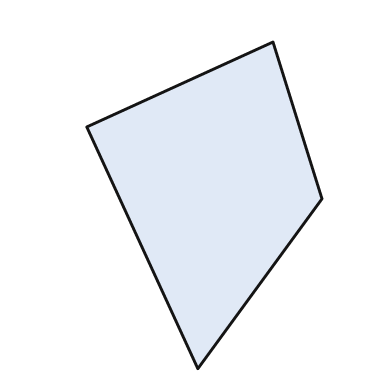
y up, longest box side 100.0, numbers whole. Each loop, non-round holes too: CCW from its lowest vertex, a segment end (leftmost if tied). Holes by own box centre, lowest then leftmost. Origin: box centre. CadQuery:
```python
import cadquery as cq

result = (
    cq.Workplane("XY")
    .moveTo(-2.0, -50.0)
    .lineTo(36.0, 2.0)
    .lineTo(21.0, 50.0)
    .lineTo(-36.0, 24.0)
    .close()
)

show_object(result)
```